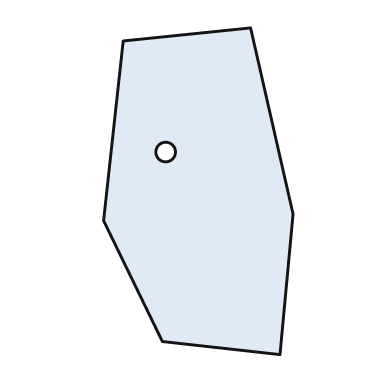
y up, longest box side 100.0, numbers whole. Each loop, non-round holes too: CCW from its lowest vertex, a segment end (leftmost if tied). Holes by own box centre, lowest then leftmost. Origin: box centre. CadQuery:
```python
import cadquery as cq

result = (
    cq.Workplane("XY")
    .moveTo(25.0, -50.0)
    .lineTo(29.0, -7.0)
    .lineTo(16.0, 50.0)
    .lineTo(-23.0, 46.0)
    .lineTo(-29.0, -9.0)
    .lineTo(-11.0, -46.0)
    .close()
    .moveTo(-10.0, 12.0)
    .circle(3.0)
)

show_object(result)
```